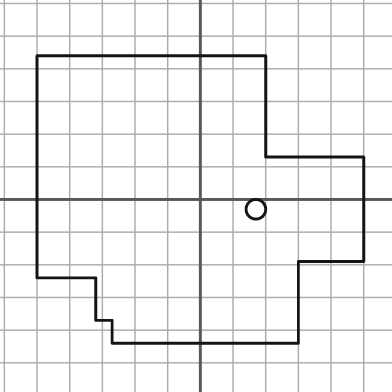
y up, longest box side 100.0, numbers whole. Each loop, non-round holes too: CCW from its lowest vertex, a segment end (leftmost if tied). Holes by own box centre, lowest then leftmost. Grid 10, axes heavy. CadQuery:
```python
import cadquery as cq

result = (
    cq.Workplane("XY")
    .moveTo(-27.0, -44.0)
    .lineTo(30.0, -44.0)
    .lineTo(30.0, -19.0)
    .lineTo(50.0, -19.0)
    .lineTo(50.0, 13.0)
    .lineTo(20.0, 13.0)
    .lineTo(20.0, 44.0)
    .lineTo(-50.0, 44.0)
    .lineTo(-50.0, -24.0)
    .lineTo(-32.0, -24.0)
    .lineTo(-32.0, -37.0)
    .lineTo(-27.0, -37.0)
    .close()
    .moveTo(17.0, -3.0)
    .circle(3.0)
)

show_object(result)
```